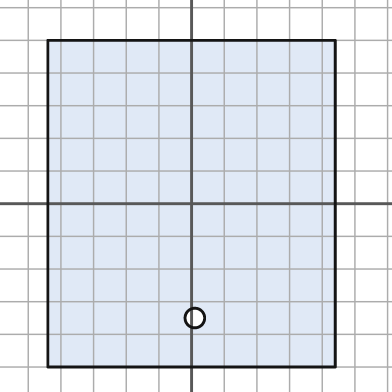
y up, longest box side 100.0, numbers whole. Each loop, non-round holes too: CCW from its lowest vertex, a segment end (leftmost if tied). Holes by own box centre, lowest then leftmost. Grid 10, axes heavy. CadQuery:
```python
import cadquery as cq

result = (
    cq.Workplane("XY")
    .moveTo(-44.0, -50.0)
    .lineTo(44.0, -50.0)
    .lineTo(44.0, 50.0)
    .lineTo(-44.0, 50.0)
    .close()
    .moveTo(1.0, -35.0)
    .circle(3.0)
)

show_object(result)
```